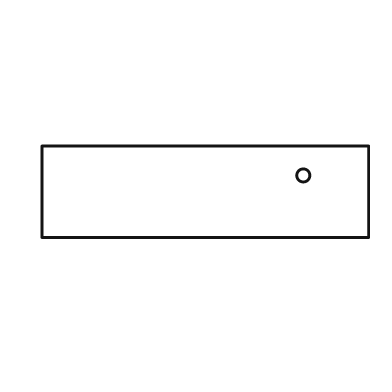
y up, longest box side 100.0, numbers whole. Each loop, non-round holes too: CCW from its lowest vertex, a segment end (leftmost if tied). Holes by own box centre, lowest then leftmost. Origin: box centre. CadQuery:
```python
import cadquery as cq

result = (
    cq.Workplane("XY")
    .moveTo(-50.0, -14.0)
    .lineTo(50.0, -14.0)
    .lineTo(50.0, 14.0)
    .lineTo(-50.0, 14.0)
    .close()
    .moveTo(30.0, 5.0)
    .circle(2.0)
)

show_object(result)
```